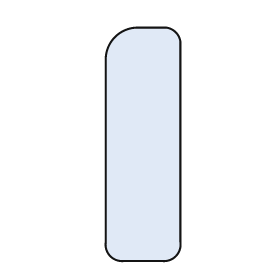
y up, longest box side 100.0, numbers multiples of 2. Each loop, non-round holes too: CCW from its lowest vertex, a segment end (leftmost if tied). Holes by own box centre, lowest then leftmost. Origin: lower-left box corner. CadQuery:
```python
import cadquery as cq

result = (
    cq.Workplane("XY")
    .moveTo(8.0, 0.0)
    .lineTo(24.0, 0.0)
    .threePointArc((30.0, 2.0), (32.0, 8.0))
    .lineTo(32.0, 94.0)
    .threePointArc((30.0, 98.0), (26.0, 100.0))
    .lineTo(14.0, 100.0)
    .threePointArc((4.0, 96.0), (0.0, 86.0))
    .lineTo(0.0, 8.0)
    .threePointArc((2.0, 2.0), (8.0, 0.0))
    .close()
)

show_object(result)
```